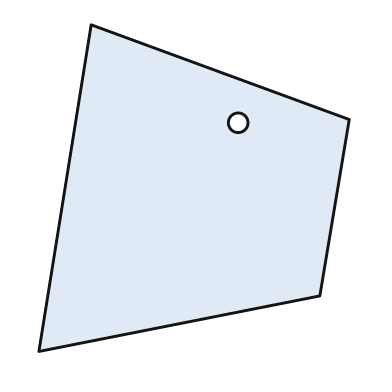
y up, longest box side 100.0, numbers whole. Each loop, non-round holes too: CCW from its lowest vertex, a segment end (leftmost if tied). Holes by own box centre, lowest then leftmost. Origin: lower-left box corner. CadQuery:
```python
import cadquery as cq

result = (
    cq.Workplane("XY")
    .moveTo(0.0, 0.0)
    .lineTo(86.0, 17.0)
    .lineTo(95.0, 71.0)
    .lineTo(16.0, 100.0)
    .close()
    .moveTo(61.0, 70.0)
    .circle(3.0)
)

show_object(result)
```